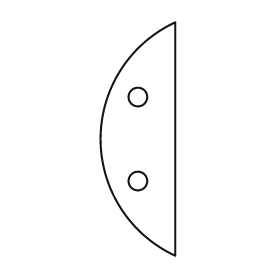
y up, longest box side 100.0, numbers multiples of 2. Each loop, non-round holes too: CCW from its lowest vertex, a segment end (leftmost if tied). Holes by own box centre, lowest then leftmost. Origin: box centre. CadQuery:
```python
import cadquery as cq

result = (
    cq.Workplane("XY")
    .moveTo(16.0, -50.0)
    .lineTo(16.0, 50.0)
    .threePointArc((-16.0, 0.0), (16.0, -50.0))
    .close()
    .moveTo(0.0, -18.0)
    .circle(4.0)
    .moveTo(0.0, 18.0)
    .circle(4.0)
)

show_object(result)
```